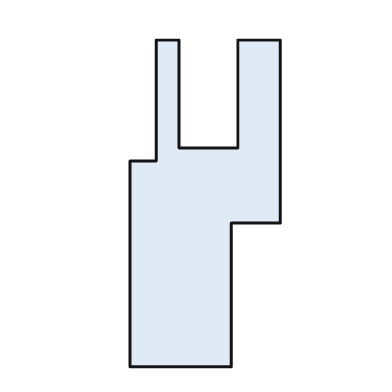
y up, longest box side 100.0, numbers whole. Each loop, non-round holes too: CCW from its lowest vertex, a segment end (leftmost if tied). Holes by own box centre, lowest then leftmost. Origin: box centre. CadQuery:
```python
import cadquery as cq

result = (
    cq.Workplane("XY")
    .moveTo(-23.0, -50.0)
    .lineTo(8.0, -50.0)
    .lineTo(8.0, -6.0)
    .lineTo(23.0, -6.0)
    .lineTo(23.0, 50.0)
    .lineTo(10.0, 50.0)
    .lineTo(10.0, 17.0)
    .lineTo(-8.0, 17.0)
    .lineTo(-8.0, 50.0)
    .lineTo(-15.0, 50.0)
    .lineTo(-15.0, 13.0)
    .lineTo(-23.0, 13.0)
    .close()
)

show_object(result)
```